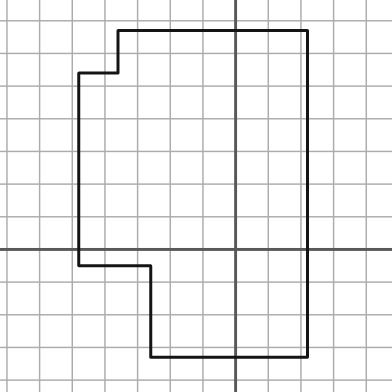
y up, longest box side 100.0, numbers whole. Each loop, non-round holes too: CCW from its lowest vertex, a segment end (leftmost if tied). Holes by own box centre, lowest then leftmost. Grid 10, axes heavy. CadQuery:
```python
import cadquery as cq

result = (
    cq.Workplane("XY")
    .moveTo(-26.0, -33.0)
    .lineTo(22.0, -33.0)
    .lineTo(22.0, 67.0)
    .lineTo(-36.0, 67.0)
    .lineTo(-36.0, 54.0)
    .lineTo(-48.0, 54.0)
    .lineTo(-48.0, -5.0)
    .lineTo(-26.0, -5.0)
    .close()
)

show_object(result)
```